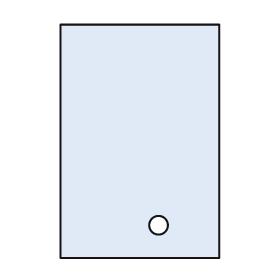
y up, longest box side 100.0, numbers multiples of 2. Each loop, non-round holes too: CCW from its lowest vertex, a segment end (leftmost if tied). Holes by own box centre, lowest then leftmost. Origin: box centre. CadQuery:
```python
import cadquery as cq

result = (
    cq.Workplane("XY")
    .moveTo(-34.0, -50.0)
    .lineTo(34.0, -50.0)
    .lineTo(34.0, 50.0)
    .lineTo(-34.0, 50.0)
    .close()
    .moveTo(8.0, -36.0)
    .circle(4.0)
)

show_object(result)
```